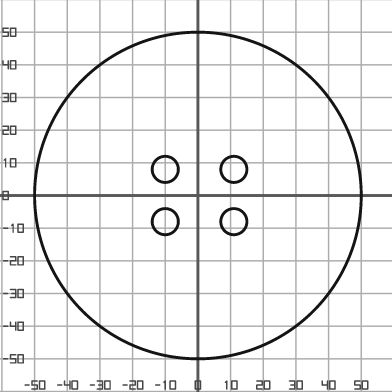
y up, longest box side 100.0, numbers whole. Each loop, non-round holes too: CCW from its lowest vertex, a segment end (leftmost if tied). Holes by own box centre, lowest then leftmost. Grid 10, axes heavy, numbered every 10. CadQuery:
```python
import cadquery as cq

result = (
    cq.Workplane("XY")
    .moveTo(0.0, 0.0)
    .circle(50.0)
    .moveTo(-10.0, -8.0)
    .circle(4.0)
    .moveTo(11.0, -8.0)
    .circle(4.0)
    .moveTo(-10.0, 8.0)
    .circle(4.0)
    .moveTo(11.0, 8.0)
    .circle(4.0)
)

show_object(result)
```